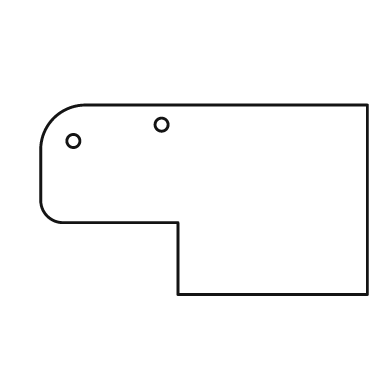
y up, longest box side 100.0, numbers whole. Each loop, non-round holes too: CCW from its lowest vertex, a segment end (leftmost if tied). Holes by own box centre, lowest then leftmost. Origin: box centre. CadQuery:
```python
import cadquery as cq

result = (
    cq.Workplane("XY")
    .moveTo(-8.0, -29.0)
    .lineTo(50.0, -29.0)
    .lineTo(50.0, 29.0)
    .lineTo(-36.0, 29.0)
    .threePointArc((-46.0, 25.0), (-50.0, 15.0))
    .lineTo(-50.0, 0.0)
    .threePointArc((-48.0, -5.0), (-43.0, -7.0))
    .lineTo(-8.0, -7.0)
    .close()
    .moveTo(-40.0, 18.0)
    .circle(2.0)
    .moveTo(-13.0, 23.0)
    .circle(2.0)
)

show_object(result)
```